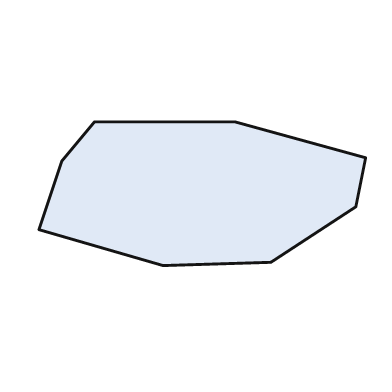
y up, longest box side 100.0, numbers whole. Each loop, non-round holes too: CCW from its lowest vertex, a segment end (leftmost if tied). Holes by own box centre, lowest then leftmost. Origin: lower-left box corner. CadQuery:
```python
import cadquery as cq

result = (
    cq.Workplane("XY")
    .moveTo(38.0, 0.0)
    .lineTo(71.0, 1.0)
    .lineTo(97.0, 18.0)
    .lineTo(100.0, 33.0)
    .lineTo(60.0, 44.0)
    .lineTo(17.0, 44.0)
    .lineTo(7.0, 32.0)
    .lineTo(0.0, 11.0)
    .close()
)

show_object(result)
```